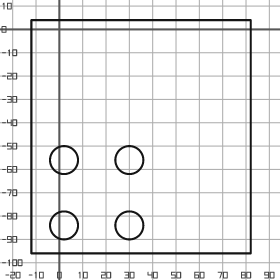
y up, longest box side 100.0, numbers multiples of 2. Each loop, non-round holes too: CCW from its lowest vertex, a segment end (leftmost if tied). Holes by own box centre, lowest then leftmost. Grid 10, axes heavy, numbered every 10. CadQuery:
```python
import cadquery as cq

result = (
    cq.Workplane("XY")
    .moveTo(-12.0, -96.0)
    .lineTo(82.0, -96.0)
    .lineTo(82.0, 4.0)
    .lineTo(-12.0, 4.0)
    .close()
    .moveTo(2.0, -84.0)
    .circle(6.0)
    .moveTo(30.0, -84.0)
    .circle(6.0)
    .moveTo(2.0, -56.0)
    .circle(6.0)
    .moveTo(30.0, -56.0)
    .circle(6.0)
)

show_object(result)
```